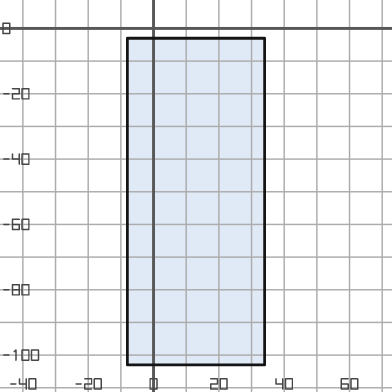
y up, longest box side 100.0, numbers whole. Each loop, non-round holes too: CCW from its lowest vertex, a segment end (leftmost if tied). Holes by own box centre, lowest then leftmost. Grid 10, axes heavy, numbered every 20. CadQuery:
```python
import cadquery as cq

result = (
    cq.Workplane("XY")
    .moveTo(-8.0, -103.0)
    .lineTo(34.0, -103.0)
    .lineTo(34.0, -3.0)
    .lineTo(-8.0, -3.0)
    .close()
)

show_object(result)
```